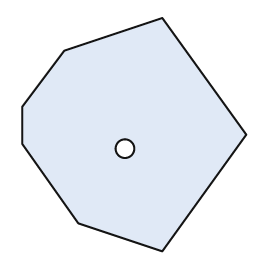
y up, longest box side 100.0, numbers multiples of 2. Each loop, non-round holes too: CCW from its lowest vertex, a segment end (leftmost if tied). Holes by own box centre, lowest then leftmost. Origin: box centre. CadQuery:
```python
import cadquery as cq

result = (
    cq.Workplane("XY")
    .moveTo(12.0, -50.0)
    .lineTo(48.0, 0.0)
    .lineTo(12.0, 50.0)
    .lineTo(-30.0, 36.0)
    .lineTo(-48.0, 12.0)
    .lineTo(-48.0, -4.0)
    .lineTo(-24.0, -38.0)
    .close()
    .moveTo(-4.0, -6.0)
    .circle(4.0)
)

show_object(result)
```